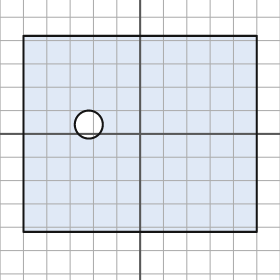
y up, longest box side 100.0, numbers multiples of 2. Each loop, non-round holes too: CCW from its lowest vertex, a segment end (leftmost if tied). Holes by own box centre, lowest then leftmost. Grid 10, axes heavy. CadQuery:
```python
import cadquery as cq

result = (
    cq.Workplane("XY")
    .moveTo(-50.0, -42.0)
    .lineTo(50.0, -42.0)
    .lineTo(50.0, 42.0)
    .lineTo(-50.0, 42.0)
    .close()
    .moveTo(-22.0, 4.0)
    .circle(6.0)
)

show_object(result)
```